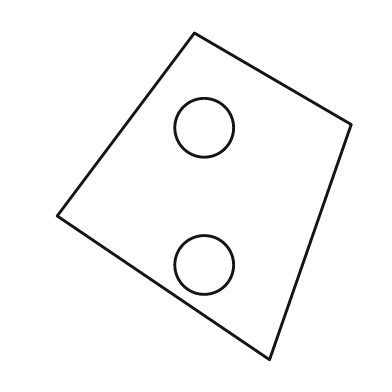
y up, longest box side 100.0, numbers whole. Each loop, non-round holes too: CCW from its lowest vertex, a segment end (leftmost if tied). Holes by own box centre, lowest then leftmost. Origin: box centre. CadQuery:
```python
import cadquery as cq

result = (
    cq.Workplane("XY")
    .moveTo(20.0, -50.0)
    .lineTo(45.0, 22.0)
    .lineTo(-3.0, 50.0)
    .lineTo(-45.0, -6.0)
    .close()
    .moveTo(0.0, -21.0)
    .circle(9.0)
    .moveTo(0.0, 21.0)
    .circle(9.0)
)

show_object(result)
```